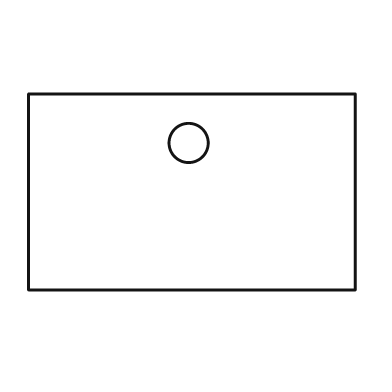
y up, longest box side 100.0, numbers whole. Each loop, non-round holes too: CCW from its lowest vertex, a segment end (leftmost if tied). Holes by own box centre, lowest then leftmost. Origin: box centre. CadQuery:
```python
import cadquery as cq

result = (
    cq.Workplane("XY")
    .moveTo(-50.0, -30.0)
    .lineTo(50.0, -30.0)
    .lineTo(50.0, 30.0)
    .lineTo(-50.0, 30.0)
    .close()
    .moveTo(-1.0, 15.0)
    .circle(6.0)
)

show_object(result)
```